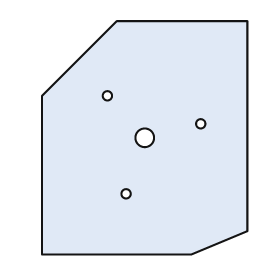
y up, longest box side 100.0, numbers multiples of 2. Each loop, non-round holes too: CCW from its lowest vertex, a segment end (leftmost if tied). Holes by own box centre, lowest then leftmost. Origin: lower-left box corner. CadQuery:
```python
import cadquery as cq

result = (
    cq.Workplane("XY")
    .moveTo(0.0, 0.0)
    .lineTo(64.0, 0.0)
    .lineTo(88.0, 10.0)
    .lineTo(88.0, 100.0)
    .lineTo(32.0, 100.0)
    .lineTo(0.0, 68.0)
    .close()
    .moveTo(36.0, 26.0)
    .circle(2.0)
    .moveTo(44.0, 50.0)
    .circle(4.0)
    .moveTo(68.0, 56.0)
    .circle(2.0)
    .moveTo(28.0, 68.0)
    .circle(2.0)
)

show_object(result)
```